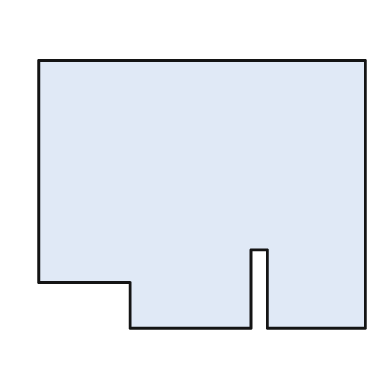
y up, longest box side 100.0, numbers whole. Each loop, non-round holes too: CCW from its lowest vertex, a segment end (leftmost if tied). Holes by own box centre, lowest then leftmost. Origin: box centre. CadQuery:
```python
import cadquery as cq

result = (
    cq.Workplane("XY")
    .moveTo(-22.0, -41.0)
    .lineTo(15.0, -41.0)
    .lineTo(15.0, -17.0)
    .lineTo(20.0, -17.0)
    .lineTo(20.0, -41.0)
    .lineTo(50.0, -41.0)
    .lineTo(50.0, 41.0)
    .lineTo(-50.0, 41.0)
    .lineTo(-50.0, -27.0)
    .lineTo(-22.0, -27.0)
    .close()
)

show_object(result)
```